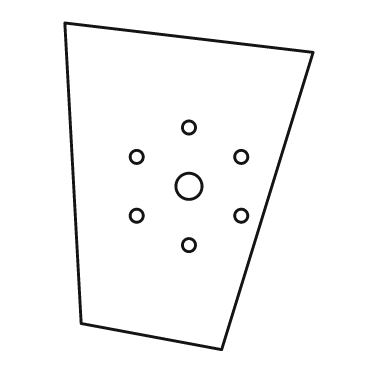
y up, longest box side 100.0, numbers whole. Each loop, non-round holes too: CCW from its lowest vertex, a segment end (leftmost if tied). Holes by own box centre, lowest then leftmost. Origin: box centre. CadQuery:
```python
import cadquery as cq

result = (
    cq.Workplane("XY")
    .moveTo(10.0, -50.0)
    .lineTo(38.0, 41.0)
    .lineTo(-38.0, 50.0)
    .lineTo(-33.0, -42.0)
    .close()
    .moveTo(0.0, -18.0)
    .circle(2.0)
    .moveTo(-16.0, -9.0)
    .circle(2.0)
    .moveTo(16.0, -9.0)
    .circle(2.0)
    .moveTo(0.0, 0.0)
    .circle(4.0)
    .moveTo(-16.0, 9.0)
    .circle(2.0)
    .moveTo(16.0, 9.0)
    .circle(2.0)
    .moveTo(0.0, 18.0)
    .circle(2.0)
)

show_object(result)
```